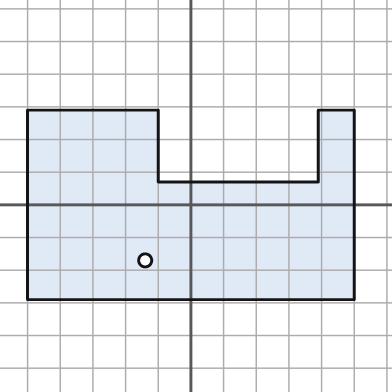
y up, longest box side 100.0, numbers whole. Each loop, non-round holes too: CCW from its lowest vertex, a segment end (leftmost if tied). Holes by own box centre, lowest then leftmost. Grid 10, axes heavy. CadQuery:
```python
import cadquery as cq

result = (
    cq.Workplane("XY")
    .moveTo(-50.0, -29.0)
    .lineTo(50.0, -29.0)
    .lineTo(50.0, 29.0)
    .lineTo(39.0, 29.0)
    .lineTo(39.0, 7.0)
    .lineTo(-10.0, 7.0)
    .lineTo(-10.0, 29.0)
    .lineTo(-50.0, 29.0)
    .close()
    .moveTo(-14.0, -17.0)
    .circle(2.0)
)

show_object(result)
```